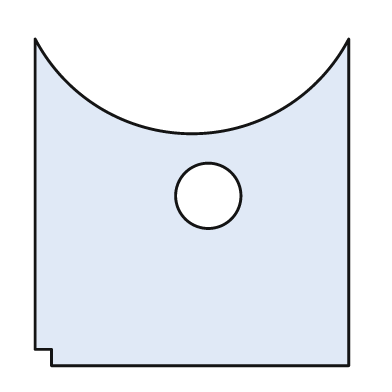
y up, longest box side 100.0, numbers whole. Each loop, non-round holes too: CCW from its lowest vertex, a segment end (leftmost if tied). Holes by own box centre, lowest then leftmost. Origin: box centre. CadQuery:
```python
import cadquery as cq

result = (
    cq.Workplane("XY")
    .moveTo(-43.0, -50.0)
    .lineTo(48.0, -50.0)
    .lineTo(48.0, 50.0)
    .threePointArc((0.0, 21.0), (-48.0, 50.0))
    .lineTo(-48.0, -45.0)
    .lineTo(-43.0, -45.0)
    .close()
    .moveTo(5.0, 2.0)
    .circle(10.0)
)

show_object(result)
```